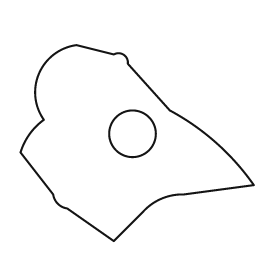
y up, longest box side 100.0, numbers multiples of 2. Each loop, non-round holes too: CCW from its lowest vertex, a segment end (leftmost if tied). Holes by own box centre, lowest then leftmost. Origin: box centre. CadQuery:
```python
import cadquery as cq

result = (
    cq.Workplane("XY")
    .moveTo(-10.0, -42.0)
    .lineTo(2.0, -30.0)
    .threePointArc((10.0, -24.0), (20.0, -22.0))
    .lineTo(50.0, -18.0)
    .threePointArc((34.0, 0.0), (14.0, 14.0))
    .lineTo(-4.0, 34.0)
    .threePointArc((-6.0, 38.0), (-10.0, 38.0))
    .lineTo(-26.0, 42.0)
    .threePointArc((-42.0, 30.0), (-40.0, 10.0))
    .threePointArc((-46.0, 4.0), (-50.0, -4.0))
    .lineTo(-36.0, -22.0)
    .threePointArc((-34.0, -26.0), (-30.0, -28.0))
    .close()
    .moveTo(-2.0, 4.0)
    .circle(10.0)
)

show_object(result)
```